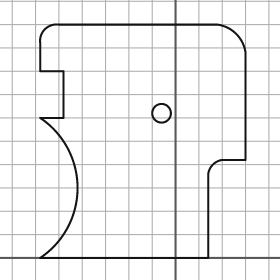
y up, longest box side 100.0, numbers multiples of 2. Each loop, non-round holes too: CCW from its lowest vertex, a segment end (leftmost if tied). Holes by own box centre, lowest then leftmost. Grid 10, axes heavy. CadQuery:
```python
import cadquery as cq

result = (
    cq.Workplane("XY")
    .moveTo(-58.0, 0.0)
    .lineTo(14.0, 0.0)
    .lineTo(14.0, 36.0)
    .threePointArc((16.0, 40.0), (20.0, 42.0))
    .lineTo(30.0, 42.0)
    .lineTo(30.0, 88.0)
    .threePointArc((26.0, 96.0), (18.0, 100.0))
    .lineTo(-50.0, 100.0)
    .threePointArc((-56.0, 98.0), (-58.0, 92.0))
    .lineTo(-58.0, 80.0)
    .lineTo(-48.0, 80.0)
    .lineTo(-48.0, 60.0)
    .lineTo(-58.0, 60.0)
    .threePointArc((-42.0, 30.0), (-58.0, 0.0))
    .close()
    .moveTo(-6.0, 62.0)
    .circle(4.0)
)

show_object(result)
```